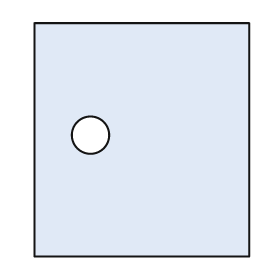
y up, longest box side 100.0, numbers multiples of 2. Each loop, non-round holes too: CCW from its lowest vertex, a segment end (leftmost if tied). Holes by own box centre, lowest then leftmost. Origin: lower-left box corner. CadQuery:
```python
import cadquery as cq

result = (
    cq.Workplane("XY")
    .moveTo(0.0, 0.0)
    .lineTo(92.0, 0.0)
    .lineTo(92.0, 100.0)
    .lineTo(0.0, 100.0)
    .close()
    .moveTo(24.0, 52.0)
    .circle(8.0)
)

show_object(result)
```